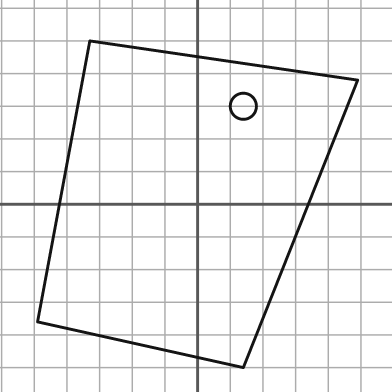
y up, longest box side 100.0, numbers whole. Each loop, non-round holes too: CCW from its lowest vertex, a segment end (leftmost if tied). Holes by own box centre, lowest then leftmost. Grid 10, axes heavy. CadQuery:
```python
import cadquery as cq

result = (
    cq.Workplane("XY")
    .moveTo(14.0, -50.0)
    .lineTo(49.0, 38.0)
    .lineTo(-33.0, 50.0)
    .lineTo(-49.0, -36.0)
    .close()
    .moveTo(14.0, 30.0)
    .circle(4.0)
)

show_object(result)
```